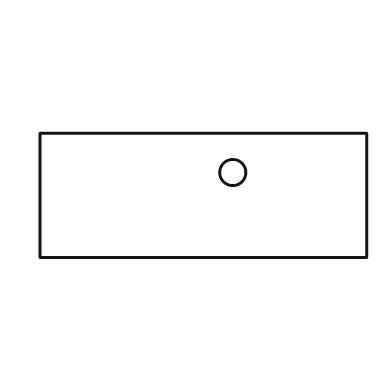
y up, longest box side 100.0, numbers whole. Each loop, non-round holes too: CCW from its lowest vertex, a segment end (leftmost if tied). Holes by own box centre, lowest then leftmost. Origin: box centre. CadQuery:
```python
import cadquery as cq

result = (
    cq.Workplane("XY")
    .moveTo(-50.0, -19.0)
    .lineTo(50.0, -19.0)
    .lineTo(50.0, 19.0)
    .lineTo(-50.0, 19.0)
    .close()
    .moveTo(9.0, 7.0)
    .circle(4.0)
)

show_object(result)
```